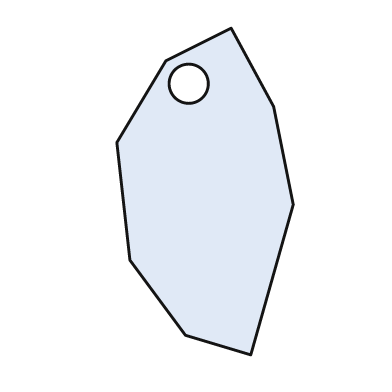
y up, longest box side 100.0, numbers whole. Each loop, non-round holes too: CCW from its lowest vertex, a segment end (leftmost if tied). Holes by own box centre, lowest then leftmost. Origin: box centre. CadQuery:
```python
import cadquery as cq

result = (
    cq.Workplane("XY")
    .moveTo(14.0, -50.0)
    .lineTo(27.0, -4.0)
    .lineTo(21.0, 26.0)
    .lineTo(8.0, 50.0)
    .lineTo(-12.0, 40.0)
    .lineTo(-27.0, 15.0)
    .lineTo(-23.0, -21.0)
    .lineTo(-6.0, -44.0)
    .close()
    .moveTo(-5.0, 33.0)
    .circle(6.0)
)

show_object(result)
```